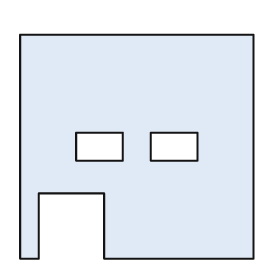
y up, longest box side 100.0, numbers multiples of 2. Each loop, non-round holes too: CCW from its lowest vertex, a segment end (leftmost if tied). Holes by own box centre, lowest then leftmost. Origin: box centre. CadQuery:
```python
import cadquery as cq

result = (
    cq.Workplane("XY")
    .moveTo(-50.0, -48.0)
    .lineTo(-42.0, -48.0)
    .lineTo(-42.0, -20.0)
    .lineTo(-14.0, -20.0)
    .lineTo(-14.0, -48.0)
    .lineTo(50.0, -48.0)
    .lineTo(50.0, 48.0)
    .lineTo(-50.0, 48.0)
    .close()
    .moveTo(-26.0, -6.0)
    .lineTo(-6.0, -6.0)
    .lineTo(-6.0, 6.0)
    .lineTo(-26.0, 6.0)
    .close()
    .moveTo(6.0, -6.0)
    .lineTo(26.0, -6.0)
    .lineTo(26.0, 6.0)
    .lineTo(6.0, 6.0)
    .close()
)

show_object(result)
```